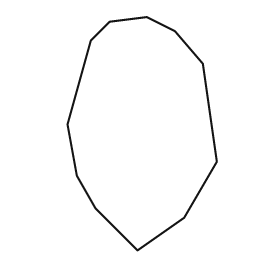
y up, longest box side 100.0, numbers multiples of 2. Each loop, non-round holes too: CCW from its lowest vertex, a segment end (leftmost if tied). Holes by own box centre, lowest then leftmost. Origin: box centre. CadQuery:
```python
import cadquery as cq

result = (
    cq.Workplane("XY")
    .moveTo(-2.0, -50.0)
    .lineTo(18.0, -36.0)
    .lineTo(32.0, -12.0)
    .lineTo(26.0, 30.0)
    .lineTo(14.0, 44.0)
    .lineTo(2.0, 50.0)
    .lineTo(-14.0, 48.0)
    .lineTo(-22.0, 40.0)
    .lineTo(-32.0, 4.0)
    .lineTo(-28.0, -18.0)
    .lineTo(-20.0, -32.0)
    .close()
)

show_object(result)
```